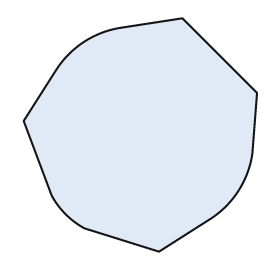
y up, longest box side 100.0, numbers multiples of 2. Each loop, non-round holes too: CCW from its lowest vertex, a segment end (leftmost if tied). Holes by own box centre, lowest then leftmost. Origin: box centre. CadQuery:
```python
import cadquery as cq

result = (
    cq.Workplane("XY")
    .moveTo(8.0, -50.0)
    .lineTo(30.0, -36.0)
    .threePointArc((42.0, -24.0), (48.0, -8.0))
    .lineTo(50.0, 18.0)
    .lineTo(18.0, 50.0)
    .lineTo(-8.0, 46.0)
    .threePointArc((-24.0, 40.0), (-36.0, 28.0))
    .lineTo(-50.0, 6.0)
    .lineTo(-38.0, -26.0)
    .threePointArc((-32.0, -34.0), (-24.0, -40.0))
    .close()
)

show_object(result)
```